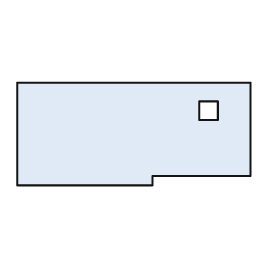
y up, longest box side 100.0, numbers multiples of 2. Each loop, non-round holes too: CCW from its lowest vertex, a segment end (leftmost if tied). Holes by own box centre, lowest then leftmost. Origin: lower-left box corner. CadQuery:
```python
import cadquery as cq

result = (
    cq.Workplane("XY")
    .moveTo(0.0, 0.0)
    .lineTo(58.0, 0.0)
    .lineTo(58.0, 4.0)
    .lineTo(100.0, 4.0)
    .lineTo(100.0, 44.0)
    .lineTo(0.0, 44.0)
    .close()
    .moveTo(78.0, 28.0)
    .lineTo(86.0, 28.0)
    .lineTo(86.0, 36.0)
    .lineTo(78.0, 36.0)
    .close()
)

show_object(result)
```